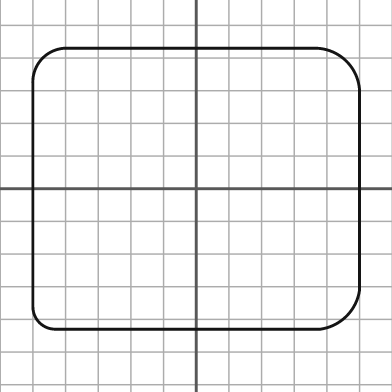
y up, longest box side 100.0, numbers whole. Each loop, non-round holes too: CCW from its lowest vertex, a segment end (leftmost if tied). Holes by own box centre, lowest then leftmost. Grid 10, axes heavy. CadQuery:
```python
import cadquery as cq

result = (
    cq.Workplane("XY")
    .moveTo(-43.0, -43.0)
    .lineTo(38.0, -43.0)
    .threePointArc((46.0, -39.0), (50.0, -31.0))
    .lineTo(50.0, 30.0)
    .threePointArc((46.0, 39.0), (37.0, 43.0))
    .lineTo(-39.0, 43.0)
    .threePointArc((-47.0, 40.0), (-50.0, 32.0))
    .lineTo(-50.0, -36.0)
    .threePointArc((-48.0, -41.0), (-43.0, -43.0))
    .close()
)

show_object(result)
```